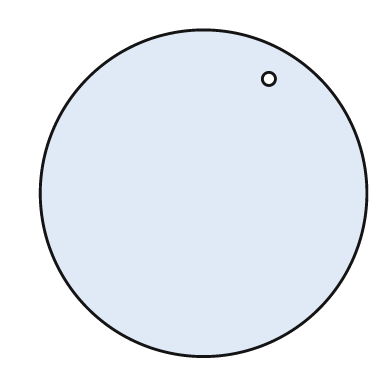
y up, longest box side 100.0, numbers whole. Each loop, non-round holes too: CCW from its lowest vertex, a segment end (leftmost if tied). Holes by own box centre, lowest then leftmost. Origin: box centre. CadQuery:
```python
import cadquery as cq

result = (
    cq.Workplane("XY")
    .moveTo(0.0, 0.0)
    .circle(50.0)
    .moveTo(20.0, 35.0)
    .circle(2.0)
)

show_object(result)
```